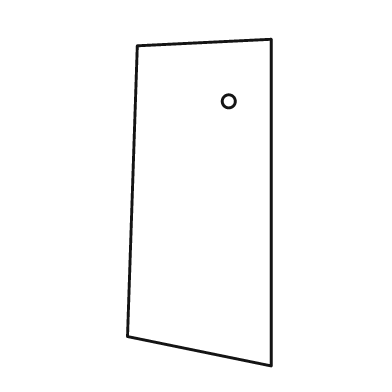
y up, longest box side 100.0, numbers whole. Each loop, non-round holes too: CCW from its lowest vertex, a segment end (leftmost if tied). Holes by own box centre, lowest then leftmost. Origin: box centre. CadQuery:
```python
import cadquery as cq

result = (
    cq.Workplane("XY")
    .moveTo(22.0, -50.0)
    .lineTo(22.0, 50.0)
    .lineTo(-19.0, 48.0)
    .lineTo(-22.0, -41.0)
    .close()
    .moveTo(9.0, 31.0)
    .circle(2.0)
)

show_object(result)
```